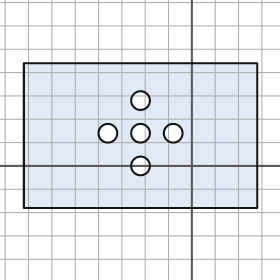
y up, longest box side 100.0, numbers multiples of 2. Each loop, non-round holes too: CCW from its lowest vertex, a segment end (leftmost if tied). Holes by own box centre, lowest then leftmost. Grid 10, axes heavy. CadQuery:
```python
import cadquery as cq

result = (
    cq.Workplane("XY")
    .moveTo(-72.0, -18.0)
    .lineTo(28.0, -18.0)
    .lineTo(28.0, 44.0)
    .lineTo(-72.0, 44.0)
    .close()
    .moveTo(-22.0, 0.0)
    .circle(4.0)
    .moveTo(-36.0, 14.0)
    .circle(4.0)
    .moveTo(-22.0, 14.0)
    .circle(4.0)
    .moveTo(-8.0, 14.0)
    .circle(4.0)
    .moveTo(-22.0, 28.0)
    .circle(4.0)
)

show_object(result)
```